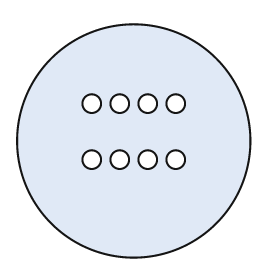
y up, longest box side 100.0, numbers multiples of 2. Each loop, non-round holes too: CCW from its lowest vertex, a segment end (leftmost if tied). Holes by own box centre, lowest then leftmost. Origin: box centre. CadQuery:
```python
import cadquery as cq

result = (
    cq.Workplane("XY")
    .moveTo(0.0, 0.0)
    .circle(50.0)
    .moveTo(-18.0, -8.0)
    .circle(4.0)
    .moveTo(-6.0, -8.0)
    .circle(4.0)
    .moveTo(6.0, -8.0)
    .circle(4.0)
    .moveTo(18.0, -8.0)
    .circle(4.0)
    .moveTo(-18.0, 16.0)
    .circle(4.0)
    .moveTo(-6.0, 16.0)
    .circle(4.0)
    .moveTo(6.0, 16.0)
    .circle(4.0)
    .moveTo(18.0, 16.0)
    .circle(4.0)
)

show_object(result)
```